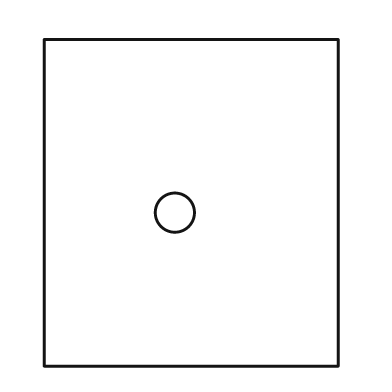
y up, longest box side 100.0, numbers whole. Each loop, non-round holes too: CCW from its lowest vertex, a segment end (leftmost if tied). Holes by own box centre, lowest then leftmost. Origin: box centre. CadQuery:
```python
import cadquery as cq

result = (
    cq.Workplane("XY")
    .moveTo(-45.0, -50.0)
    .lineTo(45.0, -50.0)
    .lineTo(45.0, 50.0)
    .lineTo(-45.0, 50.0)
    .close()
    .moveTo(-5.0, -3.0)
    .circle(6.0)
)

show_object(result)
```